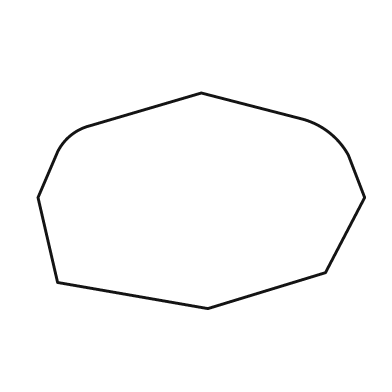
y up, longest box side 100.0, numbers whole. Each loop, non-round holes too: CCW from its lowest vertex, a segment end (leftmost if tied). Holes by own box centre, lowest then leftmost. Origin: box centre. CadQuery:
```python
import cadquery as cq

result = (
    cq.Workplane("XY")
    .moveTo(2.0, -33.0)
    .lineTo(38.0, -22.0)
    .lineTo(50.0, 1.0)
    .lineTo(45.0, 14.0)
    .threePointArc((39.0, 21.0), (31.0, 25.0))
    .lineTo(0.0, 33.0)
    .lineTo(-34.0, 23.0)
    .threePointArc((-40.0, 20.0), (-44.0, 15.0))
    .lineTo(-50.0, 1.0)
    .lineTo(-44.0, -25.0)
    .close()
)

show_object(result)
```